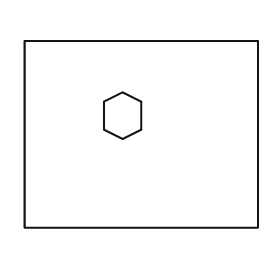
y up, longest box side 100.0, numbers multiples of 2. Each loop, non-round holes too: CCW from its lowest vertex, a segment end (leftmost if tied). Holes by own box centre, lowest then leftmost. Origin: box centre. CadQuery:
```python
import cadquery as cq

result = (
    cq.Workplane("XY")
    .moveTo(-50.0, -40.0)
    .lineTo(50.0, -40.0)
    .lineTo(50.0, 40.0)
    .lineTo(-50.0, 40.0)
    .close()
    .moveTo(-8.0, -2.0)
    .lineTo(0.0, 2.0)
    .lineTo(0.0, 14.0)
    .lineTo(-8.0, 18.0)
    .lineTo(-16.0, 14.0)
    .lineTo(-16.0, 2.0)
    .close()
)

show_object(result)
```